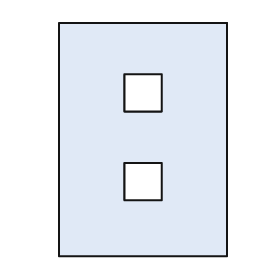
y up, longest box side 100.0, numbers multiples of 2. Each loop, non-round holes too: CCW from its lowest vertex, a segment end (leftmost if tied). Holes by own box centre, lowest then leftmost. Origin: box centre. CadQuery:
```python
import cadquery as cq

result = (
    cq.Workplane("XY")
    .moveTo(-36.0, -50.0)
    .lineTo(36.0, -50.0)
    .lineTo(36.0, 50.0)
    .lineTo(-36.0, 50.0)
    .close()
    .moveTo(-8.0, -26.0)
    .lineTo(8.0, -26.0)
    .lineTo(8.0, -10.0)
    .lineTo(-8.0, -10.0)
    .close()
    .moveTo(-8.0, 12.0)
    .lineTo(8.0, 12.0)
    .lineTo(8.0, 28.0)
    .lineTo(-8.0, 28.0)
    .close()
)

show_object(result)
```